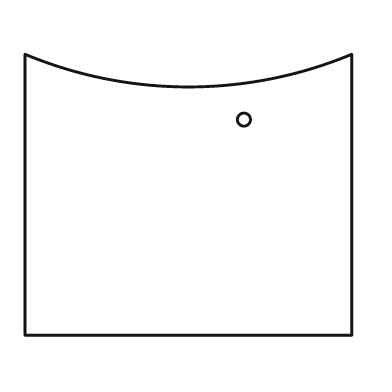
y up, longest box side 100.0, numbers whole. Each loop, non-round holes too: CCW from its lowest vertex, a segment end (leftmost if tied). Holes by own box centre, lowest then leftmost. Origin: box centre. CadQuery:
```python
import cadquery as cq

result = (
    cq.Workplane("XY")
    .moveTo(-50.0, -43.0)
    .lineTo(50.0, -43.0)
    .lineTo(50.0, 43.0)
    .threePointArc((0.0, 33.0), (-50.0, 43.0))
    .close()
    .moveTo(17.0, 23.0)
    .circle(2.0)
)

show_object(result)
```